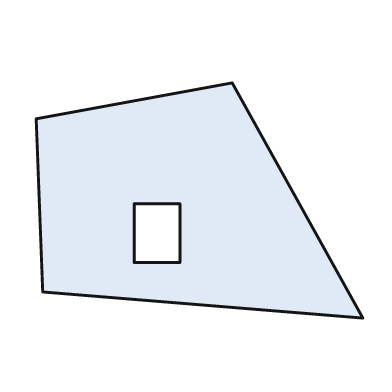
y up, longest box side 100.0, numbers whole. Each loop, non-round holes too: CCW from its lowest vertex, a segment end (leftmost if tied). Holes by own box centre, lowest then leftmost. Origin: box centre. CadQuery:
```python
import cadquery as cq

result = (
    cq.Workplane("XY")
    .moveTo(50.0, -36.0)
    .lineTo(10.0, 36.0)
    .lineTo(-50.0, 25.0)
    .lineTo(-48.0, -28.0)
    .close()
    .moveTo(-20.0, -19.0)
    .lineTo(-6.0, -19.0)
    .lineTo(-6.0, -1.0)
    .lineTo(-20.0, -1.0)
    .close()
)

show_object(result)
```